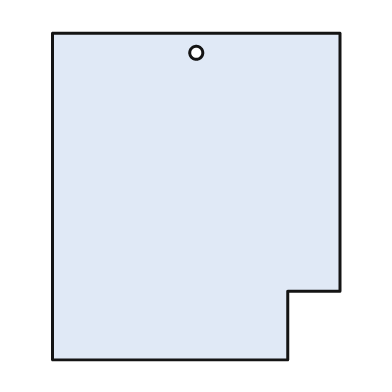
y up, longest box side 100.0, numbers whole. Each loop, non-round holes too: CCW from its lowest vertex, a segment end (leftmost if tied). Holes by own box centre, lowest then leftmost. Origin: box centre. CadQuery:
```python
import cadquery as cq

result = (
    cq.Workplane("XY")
    .moveTo(-44.0, -50.0)
    .lineTo(28.0, -50.0)
    .lineTo(28.0, -29.0)
    .lineTo(44.0, -29.0)
    .lineTo(44.0, 50.0)
    .lineTo(-44.0, 50.0)
    .close()
    .moveTo(0.0, 44.0)
    .circle(2.0)
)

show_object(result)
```